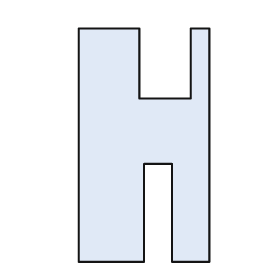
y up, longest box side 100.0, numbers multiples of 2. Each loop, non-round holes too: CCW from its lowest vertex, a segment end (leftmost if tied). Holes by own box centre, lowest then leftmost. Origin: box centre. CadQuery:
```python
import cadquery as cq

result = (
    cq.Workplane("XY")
    .moveTo(-28.0, -50.0)
    .lineTo(0.0, -50.0)
    .lineTo(0.0, -8.0)
    .lineTo(12.0, -8.0)
    .lineTo(12.0, -50.0)
    .lineTo(28.0, -50.0)
    .lineTo(28.0, 50.0)
    .lineTo(20.0, 50.0)
    .lineTo(20.0, 20.0)
    .lineTo(-2.0, 20.0)
    .lineTo(-2.0, 50.0)
    .lineTo(-28.0, 50.0)
    .close()
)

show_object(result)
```